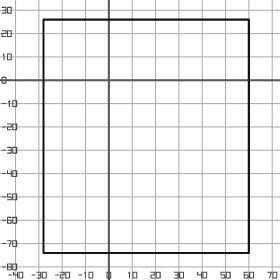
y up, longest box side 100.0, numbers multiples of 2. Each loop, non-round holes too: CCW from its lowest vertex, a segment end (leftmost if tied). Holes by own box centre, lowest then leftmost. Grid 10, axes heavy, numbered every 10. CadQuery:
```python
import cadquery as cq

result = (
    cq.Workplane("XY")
    .moveTo(-28.0, -74.0)
    .lineTo(60.0, -74.0)
    .lineTo(60.0, 26.0)
    .lineTo(-28.0, 26.0)
    .close()
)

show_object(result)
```